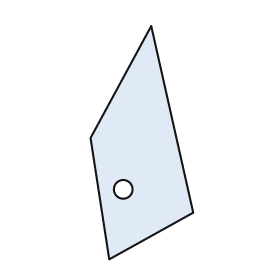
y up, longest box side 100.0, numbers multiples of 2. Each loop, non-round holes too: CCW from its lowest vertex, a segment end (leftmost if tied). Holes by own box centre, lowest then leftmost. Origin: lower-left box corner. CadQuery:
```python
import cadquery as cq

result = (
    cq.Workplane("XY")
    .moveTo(8.0, 0.0)
    .lineTo(44.0, 20.0)
    .lineTo(26.0, 100.0)
    .lineTo(0.0, 52.0)
    .close()
    .moveTo(14.0, 30.0)
    .circle(4.0)
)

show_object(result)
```